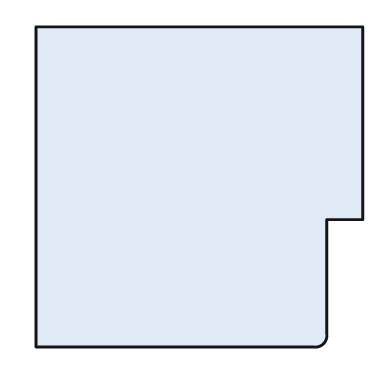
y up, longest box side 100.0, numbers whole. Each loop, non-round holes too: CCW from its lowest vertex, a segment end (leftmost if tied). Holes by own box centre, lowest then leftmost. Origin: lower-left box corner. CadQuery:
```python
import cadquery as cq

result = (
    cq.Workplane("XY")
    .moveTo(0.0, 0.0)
    .lineTo(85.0, 0.0)
    .threePointArc((88.0, 1.0), (89.0, 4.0))
    .lineTo(89.0, 39.0)
    .lineTo(100.0, 39.0)
    .lineTo(100.0, 98.0)
    .lineTo(0.0, 98.0)
    .close()
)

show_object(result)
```